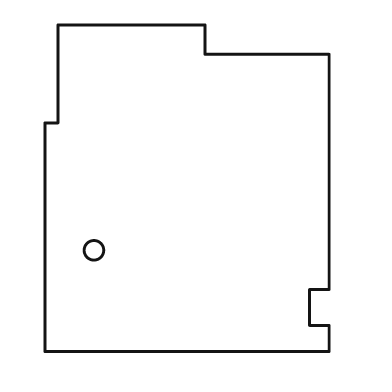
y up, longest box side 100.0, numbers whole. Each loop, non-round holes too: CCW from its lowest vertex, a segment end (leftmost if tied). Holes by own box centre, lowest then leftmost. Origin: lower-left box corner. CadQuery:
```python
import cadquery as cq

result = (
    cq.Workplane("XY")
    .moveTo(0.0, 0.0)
    .lineTo(87.0, 0.0)
    .lineTo(87.0, 8.0)
    .lineTo(81.0, 8.0)
    .lineTo(81.0, 19.0)
    .lineTo(87.0, 19.0)
    .lineTo(87.0, 91.0)
    .lineTo(49.0, 91.0)
    .lineTo(49.0, 100.0)
    .lineTo(4.0, 100.0)
    .lineTo(4.0, 70.0)
    .lineTo(0.0, 70.0)
    .close()
    .moveTo(15.0, 31.0)
    .circle(3.0)
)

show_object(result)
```